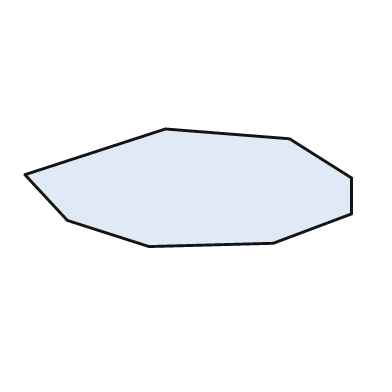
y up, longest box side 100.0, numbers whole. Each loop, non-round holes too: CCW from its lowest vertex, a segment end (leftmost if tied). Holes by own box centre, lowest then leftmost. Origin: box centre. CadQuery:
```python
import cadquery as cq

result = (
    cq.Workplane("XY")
    .moveTo(-12.0, -18.0)
    .lineTo(26.0, -17.0)
    .lineTo(50.0, -8.0)
    .lineTo(50.0, 3.0)
    .lineTo(31.0, 15.0)
    .lineTo(-7.0, 18.0)
    .lineTo(-50.0, 4.0)
    .lineTo(-37.0, -10.0)
    .close()
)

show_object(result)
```